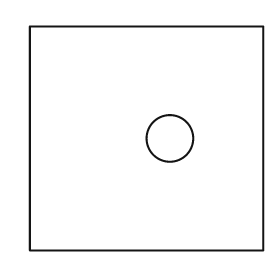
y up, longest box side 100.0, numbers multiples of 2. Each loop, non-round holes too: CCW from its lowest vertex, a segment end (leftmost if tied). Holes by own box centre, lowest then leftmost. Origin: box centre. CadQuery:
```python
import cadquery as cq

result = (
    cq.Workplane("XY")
    .moveTo(-50.0, -48.0)
    .lineTo(50.0, -48.0)
    .lineTo(50.0, 48.0)
    .lineTo(-50.0, 48.0)
    .close()
    .moveTo(10.0, 0.0)
    .circle(10.0)
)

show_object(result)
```